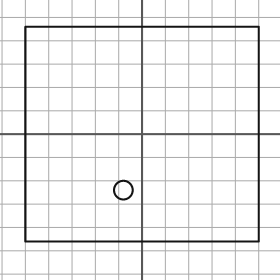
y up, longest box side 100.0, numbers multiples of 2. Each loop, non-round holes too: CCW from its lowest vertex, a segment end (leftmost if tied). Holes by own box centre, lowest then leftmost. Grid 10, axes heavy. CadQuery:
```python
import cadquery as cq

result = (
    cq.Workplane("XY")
    .moveTo(-50.0, -46.0)
    .lineTo(50.0, -46.0)
    .lineTo(50.0, 46.0)
    .lineTo(-50.0, 46.0)
    .close()
    .moveTo(-8.0, -24.0)
    .circle(4.0)
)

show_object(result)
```